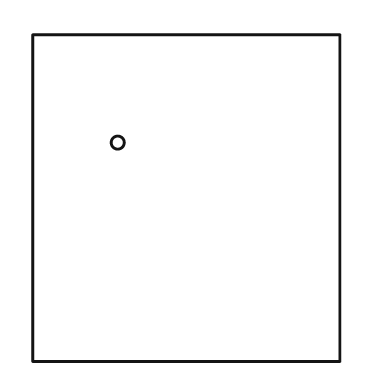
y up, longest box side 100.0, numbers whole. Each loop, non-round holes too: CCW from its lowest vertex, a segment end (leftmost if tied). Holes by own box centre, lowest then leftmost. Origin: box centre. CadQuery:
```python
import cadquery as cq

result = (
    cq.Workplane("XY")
    .moveTo(-47.0, -50.0)
    .lineTo(47.0, -50.0)
    .lineTo(47.0, 50.0)
    .lineTo(-47.0, 50.0)
    .close()
    .moveTo(-21.0, 17.0)
    .circle(2.0)
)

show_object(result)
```